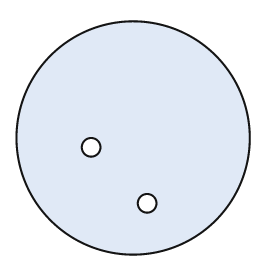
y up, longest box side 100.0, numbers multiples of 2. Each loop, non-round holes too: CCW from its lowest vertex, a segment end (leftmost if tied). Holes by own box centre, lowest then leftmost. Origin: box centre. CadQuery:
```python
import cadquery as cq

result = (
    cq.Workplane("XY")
    .moveTo(0.0, 0.0)
    .circle(50.0)
    .moveTo(6.0, -28.0)
    .circle(4.0)
    .moveTo(-18.0, -4.0)
    .circle(4.0)
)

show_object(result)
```